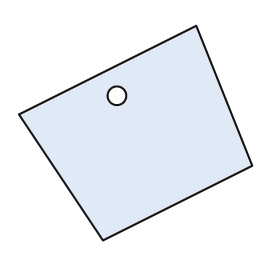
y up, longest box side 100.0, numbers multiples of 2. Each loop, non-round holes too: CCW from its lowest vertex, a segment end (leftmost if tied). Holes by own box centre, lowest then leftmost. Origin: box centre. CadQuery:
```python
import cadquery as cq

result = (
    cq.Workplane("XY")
    .moveTo(-14.0, -46.0)
    .lineTo(50.0, -14.0)
    .lineTo(26.0, 46.0)
    .lineTo(-50.0, 8.0)
    .close()
    .moveTo(-8.0, 16.0)
    .circle(4.0)
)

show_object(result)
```